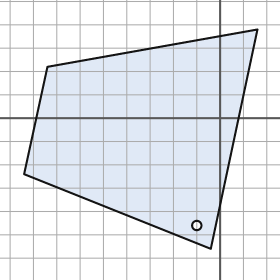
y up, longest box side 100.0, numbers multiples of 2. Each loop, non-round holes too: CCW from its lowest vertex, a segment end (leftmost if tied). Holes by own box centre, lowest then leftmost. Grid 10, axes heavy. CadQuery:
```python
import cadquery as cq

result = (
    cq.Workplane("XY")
    .moveTo(-4.0, -56.0)
    .lineTo(16.0, 38.0)
    .lineTo(-74.0, 22.0)
    .lineTo(-84.0, -24.0)
    .close()
    .moveTo(-10.0, -46.0)
    .circle(2.0)
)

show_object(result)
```